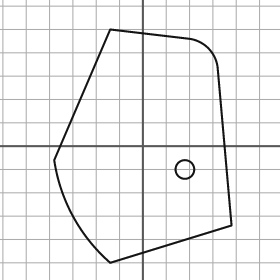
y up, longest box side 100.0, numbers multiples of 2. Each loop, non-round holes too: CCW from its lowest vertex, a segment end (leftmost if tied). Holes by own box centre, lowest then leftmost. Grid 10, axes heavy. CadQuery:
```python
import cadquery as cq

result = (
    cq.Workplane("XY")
    .moveTo(-14.0, -50.0)
    .lineTo(38.0, -34.0)
    .lineTo(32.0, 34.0)
    .threePointArc((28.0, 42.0), (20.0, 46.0))
    .lineTo(-14.0, 50.0)
    .lineTo(-38.0, -6.0)
    .threePointArc((-30.0, -30.0), (-14.0, -50.0))
    .close()
    .moveTo(18.0, -10.0)
    .circle(4.0)
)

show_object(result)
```